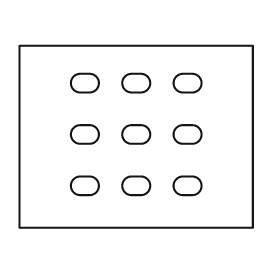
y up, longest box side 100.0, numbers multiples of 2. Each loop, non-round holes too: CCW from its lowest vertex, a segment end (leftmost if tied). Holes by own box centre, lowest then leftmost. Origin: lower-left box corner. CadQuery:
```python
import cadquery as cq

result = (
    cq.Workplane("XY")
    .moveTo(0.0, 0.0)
    .lineTo(100.0, 0.0)
    .lineTo(100.0, 78.0)
    .lineTo(0.0, 78.0)
    .close()
    .moveTo(26.0, 14.0)
    .lineTo(30.0, 14.0)
    .threePointArc((34.0, 18.0), (30.0, 22.0))
    .lineTo(26.0, 22.0)
    .threePointArc((22.0, 18.0), (26.0, 14.0))
    .close()
    .moveTo(48.0, 14.0)
    .lineTo(52.0, 14.0)
    .threePointArc((56.0, 18.0), (52.0, 22.0))
    .lineTo(48.0, 22.0)
    .threePointArc((44.0, 18.0), (48.0, 14.0))
    .close()
    .moveTo(70.0, 14.0)
    .lineTo(74.0, 14.0)
    .threePointArc((78.0, 18.0), (74.0, 22.0))
    .lineTo(70.0, 22.0)
    .threePointArc((66.0, 18.0), (70.0, 14.0))
    .close()
    .moveTo(26.0, 36.0)
    .lineTo(30.0, 36.0)
    .threePointArc((34.0, 40.0), (30.0, 44.0))
    .lineTo(26.0, 44.0)
    .threePointArc((22.0, 40.0), (26.0, 36.0))
    .close()
    .moveTo(48.0, 36.0)
    .lineTo(52.0, 36.0)
    .threePointArc((56.0, 40.0), (52.0, 44.0))
    .lineTo(48.0, 44.0)
    .threePointArc((44.0, 40.0), (48.0, 36.0))
    .close()
    .moveTo(70.0, 36.0)
    .lineTo(74.0, 36.0)
    .threePointArc((78.0, 40.0), (74.0, 44.0))
    .lineTo(70.0, 44.0)
    .threePointArc((66.0, 40.0), (70.0, 36.0))
    .close()
    .moveTo(26.0, 58.0)
    .lineTo(30.0, 58.0)
    .threePointArc((34.0, 62.0), (30.0, 66.0))
    .lineTo(26.0, 66.0)
    .threePointArc((22.0, 62.0), (26.0, 58.0))
    .close()
    .moveTo(48.0, 58.0)
    .lineTo(52.0, 58.0)
    .threePointArc((56.0, 62.0), (52.0, 66.0))
    .lineTo(48.0, 66.0)
    .threePointArc((44.0, 62.0), (48.0, 58.0))
    .close()
    .moveTo(70.0, 58.0)
    .lineTo(74.0, 58.0)
    .threePointArc((78.0, 62.0), (74.0, 66.0))
    .lineTo(70.0, 66.0)
    .threePointArc((66.0, 62.0), (70.0, 58.0))
    .close()
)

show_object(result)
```